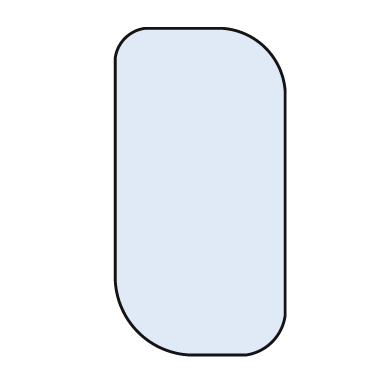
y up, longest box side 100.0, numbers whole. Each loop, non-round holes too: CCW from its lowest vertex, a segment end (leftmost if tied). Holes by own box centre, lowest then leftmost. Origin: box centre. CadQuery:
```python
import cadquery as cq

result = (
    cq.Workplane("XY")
    .moveTo(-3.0, -50.0)
    .lineTo(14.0, -50.0)
    .threePointArc((22.0, -46.0), (26.0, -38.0))
    .lineTo(26.0, 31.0)
    .threePointArc((20.0, 44.0), (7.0, 50.0))
    .lineTo(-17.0, 50.0)
    .threePointArc((-23.0, 47.0), (-26.0, 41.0))
    .lineTo(-26.0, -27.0)
    .threePointArc((-19.0, -43.0), (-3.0, -50.0))
    .close()
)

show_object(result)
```